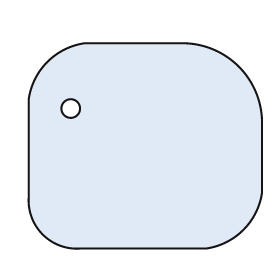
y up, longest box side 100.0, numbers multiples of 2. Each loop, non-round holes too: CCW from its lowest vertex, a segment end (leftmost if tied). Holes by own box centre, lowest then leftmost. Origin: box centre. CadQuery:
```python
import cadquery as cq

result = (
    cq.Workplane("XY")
    .moveTo(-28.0, -44.0)
    .lineTo(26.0, -44.0)
    .threePointArc((42.0, -36.0), (50.0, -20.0))
    .lineTo(50.0, 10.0)
    .threePointArc((40.0, 34.0), (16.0, 44.0))
    .lineTo(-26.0, 44.0)
    .threePointArc((-42.0, 36.0), (-50.0, 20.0))
    .lineTo(-50.0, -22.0)
    .threePointArc((-44.0, -38.0), (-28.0, -44.0))
    .close()
    .moveTo(-32.0, 16.0)
    .circle(4.0)
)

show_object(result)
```